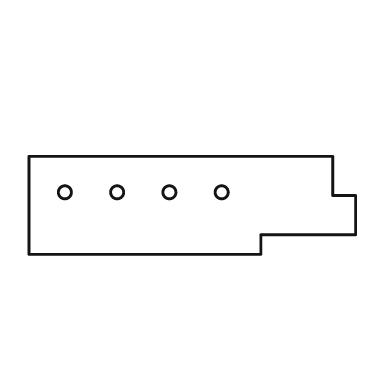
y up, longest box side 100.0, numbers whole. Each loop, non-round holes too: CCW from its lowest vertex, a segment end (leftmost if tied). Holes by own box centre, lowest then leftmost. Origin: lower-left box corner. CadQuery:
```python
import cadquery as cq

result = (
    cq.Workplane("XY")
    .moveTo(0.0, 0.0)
    .lineTo(71.0, 0.0)
    .lineTo(71.0, 6.0)
    .lineTo(100.0, 6.0)
    .lineTo(100.0, 18.0)
    .lineTo(93.0, 18.0)
    .lineTo(93.0, 30.0)
    .lineTo(0.0, 30.0)
    .close()
    .moveTo(11.0, 19.0)
    .circle(2.0)
    .moveTo(27.0, 19.0)
    .circle(2.0)
    .moveTo(43.0, 19.0)
    .circle(2.0)
    .moveTo(59.0, 19.0)
    .circle(2.0)
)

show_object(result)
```